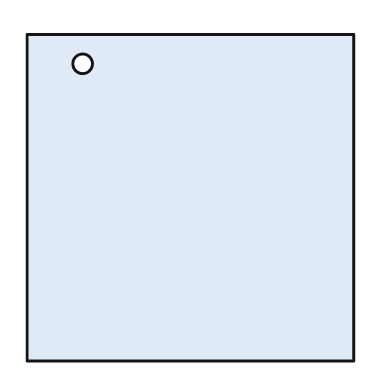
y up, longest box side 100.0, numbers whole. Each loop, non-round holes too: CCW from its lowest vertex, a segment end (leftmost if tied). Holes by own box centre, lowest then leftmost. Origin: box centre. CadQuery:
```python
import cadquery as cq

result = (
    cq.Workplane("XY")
    .moveTo(-50.0, -50.0)
    .lineTo(50.0, -50.0)
    .lineTo(50.0, 50.0)
    .lineTo(-50.0, 50.0)
    .close()
    .moveTo(-33.0, 41.0)
    .circle(3.0)
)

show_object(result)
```